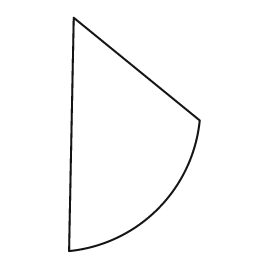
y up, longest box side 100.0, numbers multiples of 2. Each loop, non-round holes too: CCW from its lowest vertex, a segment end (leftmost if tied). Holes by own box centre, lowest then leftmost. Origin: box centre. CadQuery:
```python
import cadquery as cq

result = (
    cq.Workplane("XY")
    .moveTo(-28.0, -50.0)
    .threePointArc((10.0, -32.0), (28.0, 6.0))
    .lineTo(-26.0, 50.0)
    .close()
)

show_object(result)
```